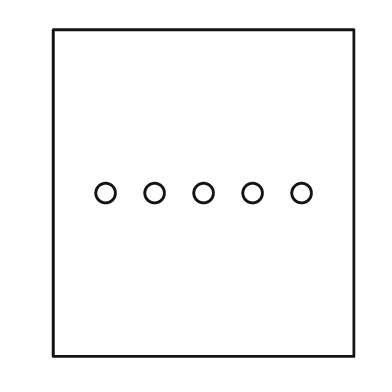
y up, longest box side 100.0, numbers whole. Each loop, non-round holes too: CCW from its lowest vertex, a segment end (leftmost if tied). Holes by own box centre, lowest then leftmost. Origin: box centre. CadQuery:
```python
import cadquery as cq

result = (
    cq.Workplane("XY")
    .moveTo(-46.0, -50.0)
    .lineTo(46.0, -50.0)
    .lineTo(46.0, 50.0)
    .lineTo(-46.0, 50.0)
    .close()
    .moveTo(-30.0, 0.0)
    .circle(3.0)
    .moveTo(-15.0, 0.0)
    .circle(3.0)
    .moveTo(0.0, 0.0)
    .circle(3.0)
    .moveTo(15.0, 0.0)
    .circle(3.0)
    .moveTo(30.0, 0.0)
    .circle(3.0)
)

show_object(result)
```